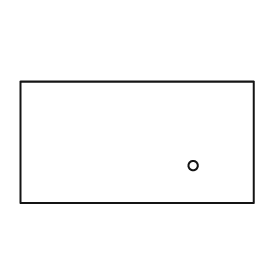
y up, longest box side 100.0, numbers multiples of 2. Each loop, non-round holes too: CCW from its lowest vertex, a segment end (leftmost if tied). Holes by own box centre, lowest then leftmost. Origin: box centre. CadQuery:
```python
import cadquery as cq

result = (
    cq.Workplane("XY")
    .moveTo(-50.0, -26.0)
    .lineTo(50.0, -26.0)
    .lineTo(50.0, 26.0)
    .lineTo(-50.0, 26.0)
    .close()
    .moveTo(24.0, -10.0)
    .circle(2.0)
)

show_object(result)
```